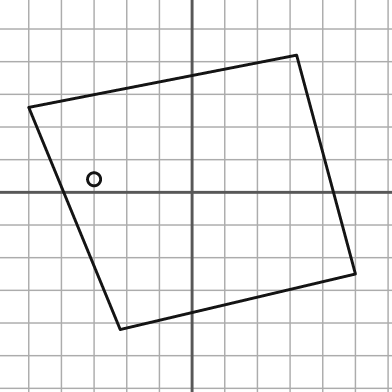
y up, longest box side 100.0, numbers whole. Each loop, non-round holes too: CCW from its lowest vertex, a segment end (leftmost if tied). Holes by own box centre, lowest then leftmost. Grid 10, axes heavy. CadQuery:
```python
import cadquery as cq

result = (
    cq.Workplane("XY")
    .moveTo(-22.0, -42.0)
    .lineTo(50.0, -25.0)
    .lineTo(32.0, 42.0)
    .lineTo(-50.0, 26.0)
    .close()
    .moveTo(-30.0, 4.0)
    .circle(2.0)
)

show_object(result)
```